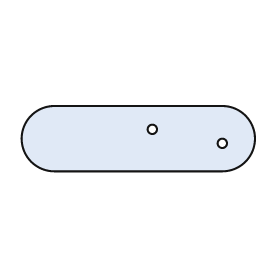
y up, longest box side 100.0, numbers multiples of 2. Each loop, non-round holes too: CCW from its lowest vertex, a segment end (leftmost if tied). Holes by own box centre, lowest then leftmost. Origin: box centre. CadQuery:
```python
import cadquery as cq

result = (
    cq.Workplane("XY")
    .moveTo(-36.0, -14.0)
    .lineTo(36.0, -14.0)
    .threePointArc((50.0, 0.0), (36.0, 14.0))
    .lineTo(-36.0, 14.0)
    .threePointArc((-50.0, 0.0), (-36.0, -14.0))
    .close()
    .moveTo(36.0, -2.0)
    .circle(2.0)
    .moveTo(6.0, 4.0)
    .circle(2.0)
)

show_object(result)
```